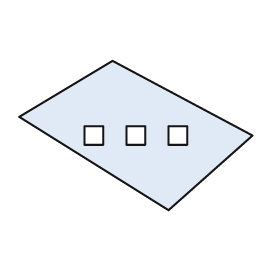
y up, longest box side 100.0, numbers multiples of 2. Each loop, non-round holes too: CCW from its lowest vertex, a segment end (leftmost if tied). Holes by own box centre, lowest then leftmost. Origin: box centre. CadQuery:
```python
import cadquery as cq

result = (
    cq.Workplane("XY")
    .moveTo(14.0, -32.0)
    .lineTo(50.0, 0.0)
    .lineTo(-10.0, 32.0)
    .lineTo(-50.0, 8.0)
    .close()
    .moveTo(-22.0, -4.0)
    .lineTo(-14.0, -4.0)
    .lineTo(-14.0, 4.0)
    .lineTo(-22.0, 4.0)
    .close()
    .moveTo(-4.0, -4.0)
    .lineTo(4.0, -4.0)
    .lineTo(4.0, 4.0)
    .lineTo(-4.0, 4.0)
    .close()
    .moveTo(14.0, -4.0)
    .lineTo(22.0, -4.0)
    .lineTo(22.0, 4.0)
    .lineTo(14.0, 4.0)
    .close()
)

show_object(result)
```